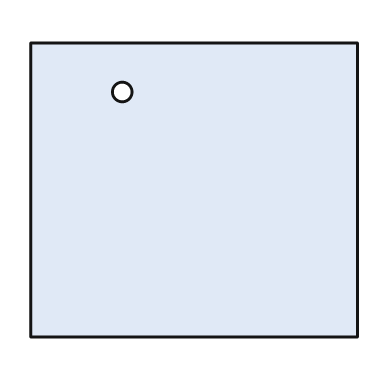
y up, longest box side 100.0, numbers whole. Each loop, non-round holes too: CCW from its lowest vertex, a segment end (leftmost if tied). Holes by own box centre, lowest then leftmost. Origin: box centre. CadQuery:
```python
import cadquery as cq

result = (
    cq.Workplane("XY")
    .moveTo(-50.0, -45.0)
    .lineTo(50.0, -45.0)
    .lineTo(50.0, 45.0)
    .lineTo(-50.0, 45.0)
    .close()
    .moveTo(-22.0, 30.0)
    .circle(3.0)
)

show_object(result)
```